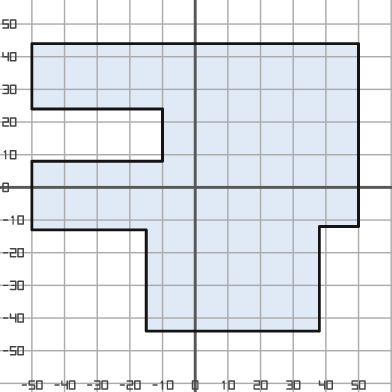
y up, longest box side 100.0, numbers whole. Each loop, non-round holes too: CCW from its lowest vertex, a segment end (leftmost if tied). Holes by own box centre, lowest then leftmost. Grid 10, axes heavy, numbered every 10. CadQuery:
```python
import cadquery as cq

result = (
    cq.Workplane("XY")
    .moveTo(-15.0, -44.0)
    .lineTo(38.0, -44.0)
    .lineTo(38.0, -12.0)
    .lineTo(50.0, -12.0)
    .lineTo(50.0, 44.0)
    .lineTo(-50.0, 44.0)
    .lineTo(-50.0, 24.0)
    .lineTo(-10.0, 24.0)
    .lineTo(-10.0, 8.0)
    .lineTo(-50.0, 8.0)
    .lineTo(-50.0, -13.0)
    .lineTo(-15.0, -13.0)
    .close()
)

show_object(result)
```